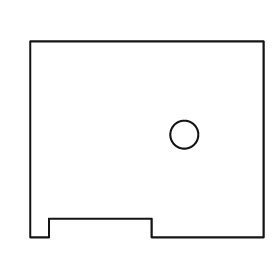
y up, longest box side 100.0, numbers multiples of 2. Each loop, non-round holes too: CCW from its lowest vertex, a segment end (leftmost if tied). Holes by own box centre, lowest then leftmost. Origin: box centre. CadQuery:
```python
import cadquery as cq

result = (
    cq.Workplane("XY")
    .moveTo(-50.0, -42.0)
    .lineTo(-42.0, -42.0)
    .lineTo(-42.0, -34.0)
    .lineTo(2.0, -34.0)
    .lineTo(2.0, -42.0)
    .lineTo(50.0, -42.0)
    .lineTo(50.0, 42.0)
    .lineTo(-50.0, 42.0)
    .close()
    .moveTo(16.0, 2.0)
    .circle(6.0)
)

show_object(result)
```